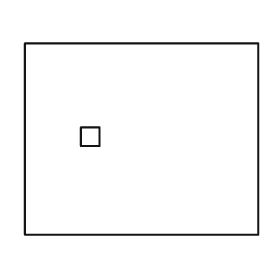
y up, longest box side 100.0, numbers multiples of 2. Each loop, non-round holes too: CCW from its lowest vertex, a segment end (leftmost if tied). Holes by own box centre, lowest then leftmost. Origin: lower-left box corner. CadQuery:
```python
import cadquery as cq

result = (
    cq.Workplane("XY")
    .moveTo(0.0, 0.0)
    .lineTo(100.0, 0.0)
    .lineTo(100.0, 82.0)
    .lineTo(0.0, 82.0)
    .close()
    .moveTo(24.0, 38.0)
    .lineTo(32.0, 38.0)
    .lineTo(32.0, 46.0)
    .lineTo(24.0, 46.0)
    .close()
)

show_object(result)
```